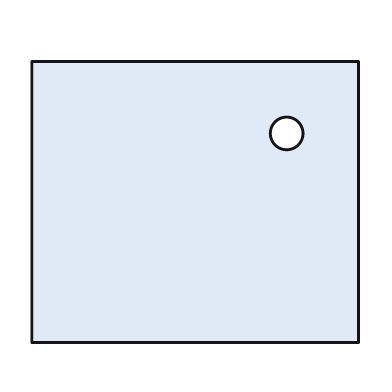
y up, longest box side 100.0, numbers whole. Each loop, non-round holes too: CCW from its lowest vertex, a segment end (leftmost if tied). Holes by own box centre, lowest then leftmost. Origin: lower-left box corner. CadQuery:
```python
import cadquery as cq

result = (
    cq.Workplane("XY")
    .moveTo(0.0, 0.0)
    .lineTo(100.0, 0.0)
    .lineTo(100.0, 86.0)
    .lineTo(0.0, 86.0)
    .close()
    .moveTo(78.0, 64.0)
    .circle(5.0)
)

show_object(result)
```